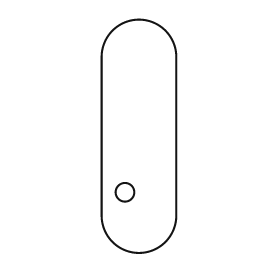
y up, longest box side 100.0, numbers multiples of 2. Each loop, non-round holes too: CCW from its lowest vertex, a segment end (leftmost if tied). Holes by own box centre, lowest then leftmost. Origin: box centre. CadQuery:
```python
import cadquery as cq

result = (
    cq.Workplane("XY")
    .moveTo(-16.0, -34.0)
    .threePointArc((0.0, -50.0), (16.0, -34.0))
    .lineTo(16.0, 34.0)
    .threePointArc((0.0, 50.0), (-16.0, 34.0))
    .close()
    .moveTo(-6.0, -24.0)
    .circle(4.0)
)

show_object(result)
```